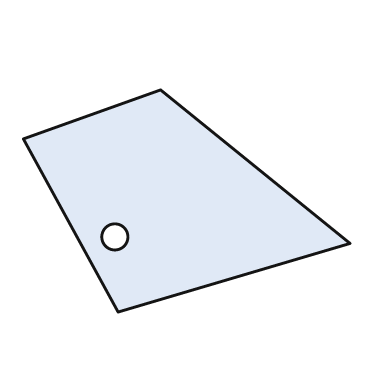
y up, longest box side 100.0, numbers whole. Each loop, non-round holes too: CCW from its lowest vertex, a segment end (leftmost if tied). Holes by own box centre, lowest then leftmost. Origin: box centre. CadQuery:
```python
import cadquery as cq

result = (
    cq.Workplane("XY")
    .moveTo(-21.0, -34.0)
    .lineTo(50.0, -13.0)
    .lineTo(-8.0, 34.0)
    .lineTo(-50.0, 19.0)
    .close()
    .moveTo(-22.0, -11.0)
    .circle(4.0)
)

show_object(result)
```